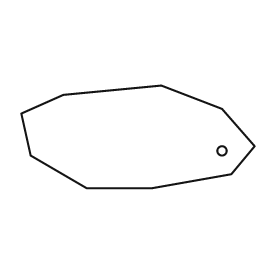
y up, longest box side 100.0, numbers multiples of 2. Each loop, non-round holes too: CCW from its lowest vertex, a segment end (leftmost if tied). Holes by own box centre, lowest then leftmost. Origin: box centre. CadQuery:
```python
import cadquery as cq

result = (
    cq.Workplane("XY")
    .moveTo(-22.0, -22.0)
    .lineTo(6.0, -22.0)
    .lineTo(40.0, -16.0)
    .lineTo(50.0, -4.0)
    .lineTo(36.0, 12.0)
    .lineTo(10.0, 22.0)
    .lineTo(-32.0, 18.0)
    .lineTo(-50.0, 10.0)
    .lineTo(-46.0, -8.0)
    .close()
    .moveTo(36.0, -6.0)
    .circle(2.0)
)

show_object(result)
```